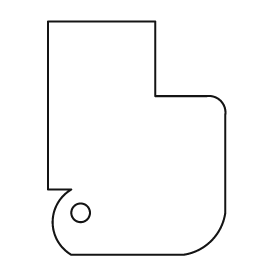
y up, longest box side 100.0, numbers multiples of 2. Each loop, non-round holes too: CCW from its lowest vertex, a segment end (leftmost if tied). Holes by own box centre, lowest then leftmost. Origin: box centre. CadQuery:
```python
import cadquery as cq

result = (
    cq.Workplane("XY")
    .moveTo(-28.0, -50.0)
    .lineTo(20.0, -50.0)
    .threePointArc((32.0, -44.0), (38.0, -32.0))
    .lineTo(38.0, 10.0)
    .threePointArc((36.0, 16.0), (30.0, 18.0))
    .lineTo(8.0, 18.0)
    .lineTo(8.0, 50.0)
    .lineTo(-38.0, 50.0)
    .lineTo(-38.0, -22.0)
    .lineTo(-28.0, -22.0)
    .threePointArc((-36.0, -36.0), (-28.0, -50.0))
    .close()
    .moveTo(-24.0, -32.0)
    .circle(4.0)
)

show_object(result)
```